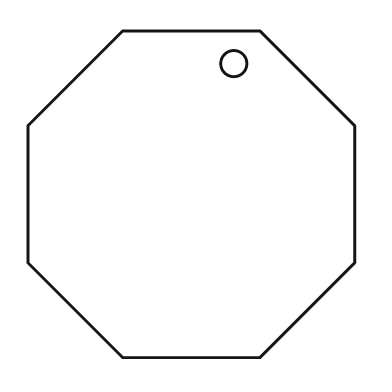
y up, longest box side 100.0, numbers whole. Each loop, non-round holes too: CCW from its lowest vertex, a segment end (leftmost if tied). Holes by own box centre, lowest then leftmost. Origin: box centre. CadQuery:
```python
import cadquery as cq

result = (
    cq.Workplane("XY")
    .moveTo(-21.0, -50.0)
    .lineTo(21.0, -50.0)
    .lineTo(50.0, -21.0)
    .lineTo(50.0, 21.0)
    .lineTo(21.0, 50.0)
    .lineTo(-21.0, 50.0)
    .lineTo(-50.0, 21.0)
    .lineTo(-50.0, -21.0)
    .close()
    .moveTo(13.0, 40.0)
    .circle(4.0)
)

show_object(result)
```